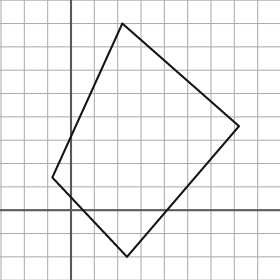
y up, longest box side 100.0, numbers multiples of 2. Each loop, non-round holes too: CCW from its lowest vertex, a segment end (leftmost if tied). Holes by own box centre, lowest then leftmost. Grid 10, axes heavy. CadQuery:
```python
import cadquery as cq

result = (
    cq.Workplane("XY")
    .moveTo(24.0, -20.0)
    .lineTo(72.0, 36.0)
    .lineTo(22.0, 80.0)
    .lineTo(-8.0, 14.0)
    .close()
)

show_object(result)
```